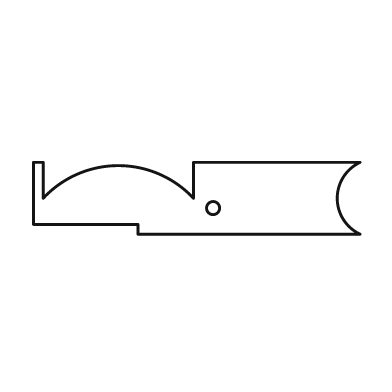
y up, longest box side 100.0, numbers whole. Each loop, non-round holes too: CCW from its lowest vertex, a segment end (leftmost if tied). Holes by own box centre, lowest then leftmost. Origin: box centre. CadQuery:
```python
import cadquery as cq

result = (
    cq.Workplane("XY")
    .moveTo(-18.0, -11.0)
    .lineTo(50.0, -11.0)
    .threePointArc((43.0, 0.0), (50.0, 11.0))
    .lineTo(-1.0, 11.0)
    .lineTo(-1.0, 0.0)
    .threePointArc((-24.0, 10.0), (-47.0, 0.0))
    .lineTo(-47.0, 11.0)
    .lineTo(-50.0, 11.0)
    .lineTo(-50.0, -8.0)
    .lineTo(-18.0, -8.0)
    .close()
    .moveTo(5.0, -3.0)
    .circle(2.0)
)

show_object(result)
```